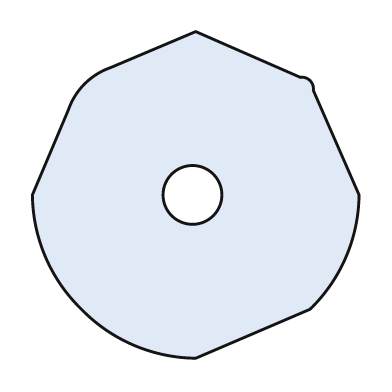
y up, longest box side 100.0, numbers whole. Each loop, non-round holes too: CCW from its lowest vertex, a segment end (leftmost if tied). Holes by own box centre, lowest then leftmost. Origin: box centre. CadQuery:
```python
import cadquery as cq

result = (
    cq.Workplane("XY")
    .moveTo(0.0, -50.0)
    .lineTo(35.0, -35.0)
    .threePointArc((46.0, -19.0), (50.0, 0.0))
    .lineTo(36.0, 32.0)
    .threePointArc((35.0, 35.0), (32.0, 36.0))
    .lineTo(0.0, 50.0)
    .lineTo(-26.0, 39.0)
    .threePointArc((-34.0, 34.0), (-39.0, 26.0))
    .lineTo(-50.0, 0.0)
    .threePointArc((-46.0, -19.0), (-35.0, -35.0))
    .threePointArc((-19.0, -46.0), (0.0, -50.0))
    .close()
    .moveTo(-1.0, 0.0)
    .circle(9.0)
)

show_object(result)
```